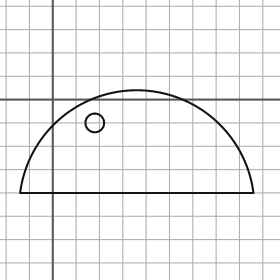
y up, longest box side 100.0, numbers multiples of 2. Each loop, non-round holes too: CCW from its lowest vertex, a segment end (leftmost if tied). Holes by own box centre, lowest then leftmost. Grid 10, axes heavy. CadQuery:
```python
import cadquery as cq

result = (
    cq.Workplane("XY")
    .moveTo(-14.0, -40.0)
    .lineTo(86.0, -40.0)
    .threePointArc((36.0, 4.0), (-14.0, -40.0))
    .close()
    .moveTo(18.0, -10.0)
    .circle(4.0)
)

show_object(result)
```